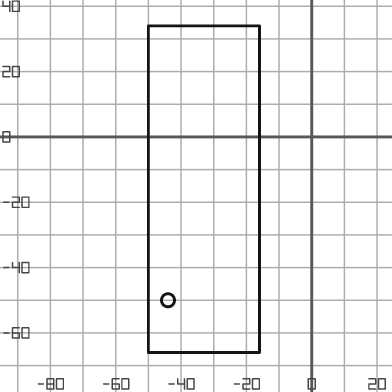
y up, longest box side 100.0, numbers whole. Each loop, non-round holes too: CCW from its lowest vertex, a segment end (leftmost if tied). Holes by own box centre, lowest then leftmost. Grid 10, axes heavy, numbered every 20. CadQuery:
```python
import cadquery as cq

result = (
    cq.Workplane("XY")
    .moveTo(-50.0, -66.0)
    .lineTo(-16.0, -66.0)
    .lineTo(-16.0, 34.0)
    .lineTo(-50.0, 34.0)
    .close()
    .moveTo(-44.0, -50.0)
    .circle(2.0)
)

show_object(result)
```